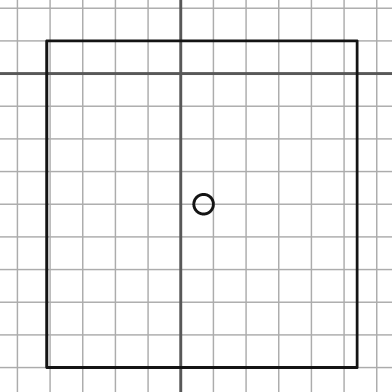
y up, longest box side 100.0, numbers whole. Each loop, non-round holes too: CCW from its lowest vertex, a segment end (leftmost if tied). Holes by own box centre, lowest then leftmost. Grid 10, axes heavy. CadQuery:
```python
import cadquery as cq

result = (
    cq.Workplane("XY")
    .moveTo(-41.0, -90.0)
    .lineTo(54.0, -90.0)
    .lineTo(54.0, 10.0)
    .lineTo(-41.0, 10.0)
    .close()
    .moveTo(7.0, -40.0)
    .circle(3.0)
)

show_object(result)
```